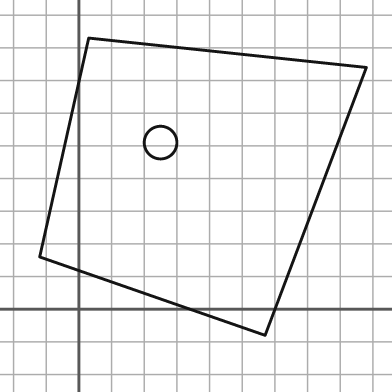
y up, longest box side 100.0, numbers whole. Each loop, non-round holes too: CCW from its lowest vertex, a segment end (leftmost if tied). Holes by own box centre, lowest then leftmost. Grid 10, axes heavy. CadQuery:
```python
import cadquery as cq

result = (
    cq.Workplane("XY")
    .moveTo(57.0, -8.0)
    .lineTo(88.0, 74.0)
    .lineTo(3.0, 83.0)
    .lineTo(-12.0, 16.0)
    .close()
    .moveTo(25.0, 51.0)
    .circle(5.0)
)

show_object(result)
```